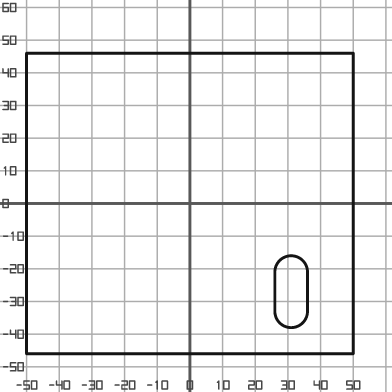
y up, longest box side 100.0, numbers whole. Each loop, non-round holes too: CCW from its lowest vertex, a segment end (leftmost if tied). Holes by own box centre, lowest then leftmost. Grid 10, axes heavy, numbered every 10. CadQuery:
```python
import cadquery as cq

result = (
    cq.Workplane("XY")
    .moveTo(-50.0, -46.0)
    .lineTo(50.0, -46.0)
    .lineTo(50.0, 46.0)
    .lineTo(-50.0, 46.0)
    .close()
    .moveTo(26.0, -33.0)
    .threePointArc((31.0, -38.0), (36.0, -33.0))
    .lineTo(36.0, -21.0)
    .threePointArc((31.0, -16.0), (26.0, -21.0))
    .close()
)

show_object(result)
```